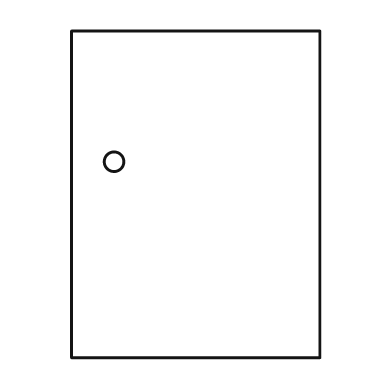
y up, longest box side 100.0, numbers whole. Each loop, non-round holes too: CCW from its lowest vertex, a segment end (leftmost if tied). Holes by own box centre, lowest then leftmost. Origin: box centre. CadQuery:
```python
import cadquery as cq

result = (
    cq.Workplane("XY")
    .moveTo(-38.0, -50.0)
    .lineTo(38.0, -50.0)
    .lineTo(38.0, 50.0)
    .lineTo(-38.0, 50.0)
    .close()
    .moveTo(-25.0, 10.0)
    .circle(3.0)
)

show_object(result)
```